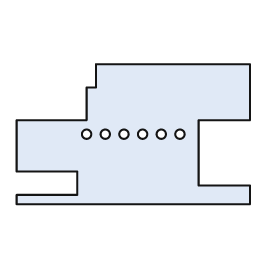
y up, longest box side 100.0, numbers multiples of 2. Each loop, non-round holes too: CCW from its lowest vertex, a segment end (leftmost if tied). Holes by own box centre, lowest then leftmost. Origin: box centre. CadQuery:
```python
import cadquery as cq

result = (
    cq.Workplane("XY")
    .moveTo(-50.0, -30.0)
    .lineTo(50.0, -30.0)
    .lineTo(50.0, -22.0)
    .lineTo(28.0, -22.0)
    .lineTo(28.0, 6.0)
    .lineTo(50.0, 6.0)
    .lineTo(50.0, 30.0)
    .lineTo(-16.0, 30.0)
    .lineTo(-16.0, 20.0)
    .lineTo(-20.0, 20.0)
    .lineTo(-20.0, 6.0)
    .lineTo(-50.0, 6.0)
    .lineTo(-50.0, -16.0)
    .lineTo(-24.0, -16.0)
    .lineTo(-24.0, -26.0)
    .lineTo(-50.0, -26.0)
    .close()
    .moveTo(-20.0, 0.0)
    .circle(2.0)
    .moveTo(-12.0, 0.0)
    .circle(2.0)
    .moveTo(-4.0, 0.0)
    .circle(2.0)
    .moveTo(4.0, 0.0)
    .circle(2.0)
    .moveTo(12.0, 0.0)
    .circle(2.0)
    .moveTo(20.0, 0.0)
    .circle(2.0)
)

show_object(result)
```